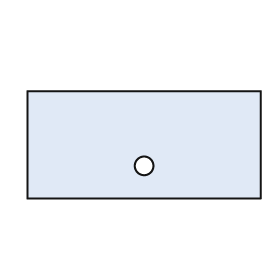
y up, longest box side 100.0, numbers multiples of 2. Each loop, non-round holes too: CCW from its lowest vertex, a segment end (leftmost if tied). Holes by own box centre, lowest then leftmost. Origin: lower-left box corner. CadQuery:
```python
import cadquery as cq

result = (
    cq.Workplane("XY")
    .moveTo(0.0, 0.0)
    .lineTo(100.0, 0.0)
    .lineTo(100.0, 46.0)
    .lineTo(0.0, 46.0)
    .close()
    .moveTo(50.0, 14.0)
    .circle(4.0)
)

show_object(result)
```